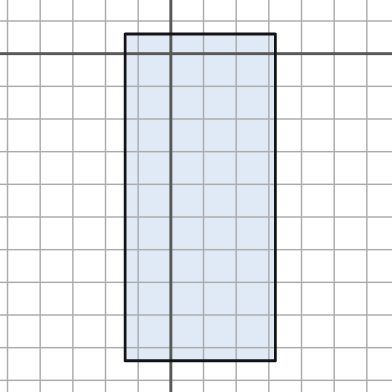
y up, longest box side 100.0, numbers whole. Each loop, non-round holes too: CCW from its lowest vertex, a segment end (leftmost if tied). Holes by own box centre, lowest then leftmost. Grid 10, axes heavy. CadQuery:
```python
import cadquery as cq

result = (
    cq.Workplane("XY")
    .moveTo(-14.0, -94.0)
    .lineTo(32.0, -94.0)
    .lineTo(32.0, 6.0)
    .lineTo(-14.0, 6.0)
    .close()
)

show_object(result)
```